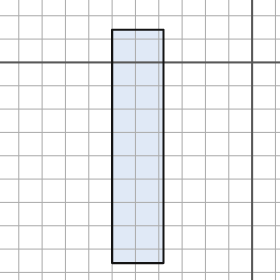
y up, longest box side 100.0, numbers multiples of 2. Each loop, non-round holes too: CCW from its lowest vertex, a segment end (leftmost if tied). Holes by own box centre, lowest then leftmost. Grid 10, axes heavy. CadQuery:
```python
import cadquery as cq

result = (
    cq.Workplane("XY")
    .moveTo(-60.0, -86.0)
    .lineTo(-38.0, -86.0)
    .lineTo(-38.0, 14.0)
    .lineTo(-60.0, 14.0)
    .close()
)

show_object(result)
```